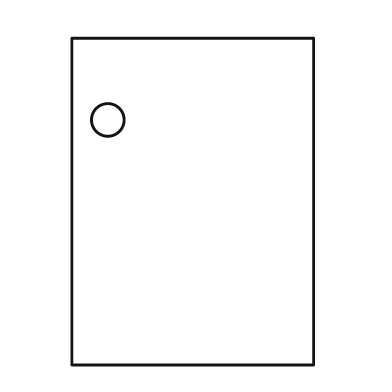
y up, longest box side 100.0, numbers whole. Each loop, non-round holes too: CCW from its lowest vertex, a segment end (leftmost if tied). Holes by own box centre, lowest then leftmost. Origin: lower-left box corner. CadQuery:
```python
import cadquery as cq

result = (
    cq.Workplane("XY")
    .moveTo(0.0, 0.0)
    .lineTo(74.0, 0.0)
    .lineTo(74.0, 100.0)
    .lineTo(0.0, 100.0)
    .close()
    .moveTo(11.0, 75.0)
    .circle(5.0)
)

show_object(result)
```